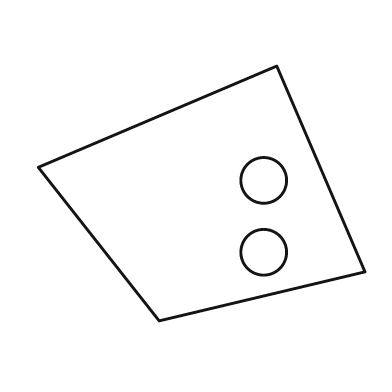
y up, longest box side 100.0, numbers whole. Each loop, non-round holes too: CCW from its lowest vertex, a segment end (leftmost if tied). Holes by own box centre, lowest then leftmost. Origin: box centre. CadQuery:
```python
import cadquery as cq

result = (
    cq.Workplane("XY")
    .moveTo(-13.0, -39.0)
    .lineTo(50.0, -24.0)
    .lineTo(23.0, 39.0)
    .lineTo(-50.0, 8.0)
    .close()
    .moveTo(19.0, -18.0)
    .circle(7.0)
    .moveTo(19.0, 4.0)
    .circle(7.0)
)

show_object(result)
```